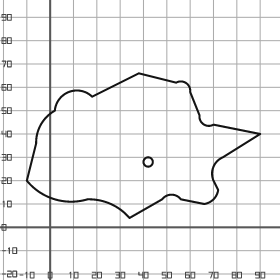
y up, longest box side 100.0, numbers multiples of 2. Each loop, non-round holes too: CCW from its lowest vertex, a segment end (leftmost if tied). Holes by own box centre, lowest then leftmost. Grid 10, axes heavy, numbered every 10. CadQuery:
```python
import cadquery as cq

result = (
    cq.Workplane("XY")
    .moveTo(34.0, 4.0)
    .lineTo(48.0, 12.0)
    .threePointArc((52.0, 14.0), (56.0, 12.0))
    .lineTo(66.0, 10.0)
    .threePointArc((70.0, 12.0), (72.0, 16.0))
    .lineTo(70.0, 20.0)
    .threePointArc((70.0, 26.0), (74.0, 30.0))
    .lineTo(90.0, 40.0)
    .lineTo(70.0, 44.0)
    .threePointArc((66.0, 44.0), (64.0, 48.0))
    .lineTo(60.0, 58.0)
    .threePointArc((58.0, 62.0), (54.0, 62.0))
    .lineTo(38.0, 66.0)
    .lineTo(18.0, 56.0)
    .threePointArc((8.0, 58.0), (2.0, 50.0))
    .threePointArc((-4.0, 44.0), (-6.0, 36.0))
    .lineTo(-10.0, 20.0)
    .threePointArc((2.0, 12.0), (16.0, 12.0))
    .threePointArc((26.0, 10.0), (34.0, 4.0))
    .close()
    .moveTo(42.0, 28.0)
    .circle(2.0)
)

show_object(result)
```